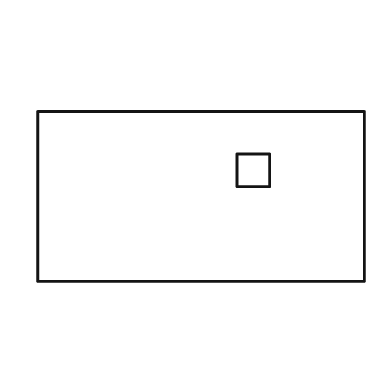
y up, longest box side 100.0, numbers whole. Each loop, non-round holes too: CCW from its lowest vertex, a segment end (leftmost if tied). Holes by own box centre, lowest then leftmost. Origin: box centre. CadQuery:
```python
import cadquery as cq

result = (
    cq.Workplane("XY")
    .moveTo(-50.0, -26.0)
    .lineTo(50.0, -26.0)
    .lineTo(50.0, 26.0)
    .lineTo(-50.0, 26.0)
    .close()
    .moveTo(11.0, 3.0)
    .lineTo(21.0, 3.0)
    .lineTo(21.0, 13.0)
    .lineTo(11.0, 13.0)
    .close()
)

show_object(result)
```